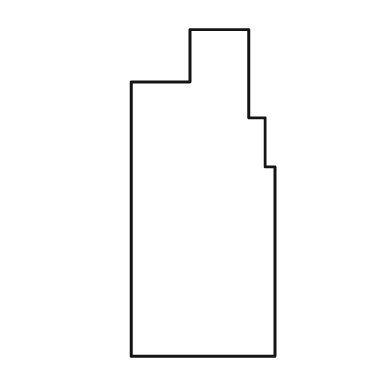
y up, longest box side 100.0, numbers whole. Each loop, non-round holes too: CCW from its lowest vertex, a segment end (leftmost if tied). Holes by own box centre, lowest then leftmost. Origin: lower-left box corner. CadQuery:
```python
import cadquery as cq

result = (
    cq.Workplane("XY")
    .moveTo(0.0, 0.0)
    .lineTo(44.0, 0.0)
    .lineTo(44.0, 58.0)
    .lineTo(41.0, 58.0)
    .lineTo(41.0, 73.0)
    .lineTo(36.0, 73.0)
    .lineTo(36.0, 100.0)
    .lineTo(18.0, 100.0)
    .lineTo(18.0, 84.0)
    .lineTo(0.0, 84.0)
    .close()
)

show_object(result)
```